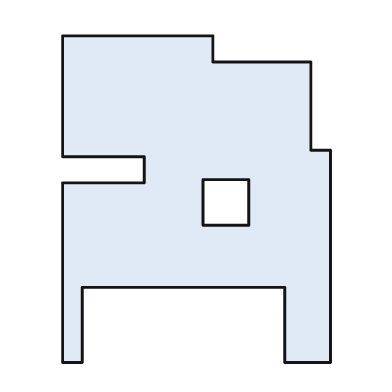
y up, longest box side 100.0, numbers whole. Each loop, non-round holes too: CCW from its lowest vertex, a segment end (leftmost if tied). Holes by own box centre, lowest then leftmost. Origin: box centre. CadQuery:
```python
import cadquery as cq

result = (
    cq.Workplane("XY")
    .moveTo(-41.0, -50.0)
    .lineTo(-35.0, -50.0)
    .lineTo(-35.0, -27.0)
    .lineTo(27.0, -27.0)
    .lineTo(27.0, -50.0)
    .lineTo(41.0, -50.0)
    .lineTo(41.0, 15.0)
    .lineTo(35.0, 15.0)
    .lineTo(35.0, 42.0)
    .lineTo(5.0, 42.0)
    .lineTo(5.0, 50.0)
    .lineTo(-41.0, 50.0)
    .lineTo(-41.0, 13.0)
    .lineTo(-16.0, 13.0)
    .lineTo(-16.0, 5.0)
    .lineTo(-41.0, 5.0)
    .close()
    .moveTo(2.0, -8.0)
    .lineTo(16.0, -8.0)
    .lineTo(16.0, 6.0)
    .lineTo(2.0, 6.0)
    .close()
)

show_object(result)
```